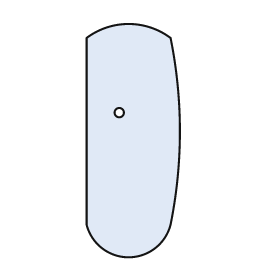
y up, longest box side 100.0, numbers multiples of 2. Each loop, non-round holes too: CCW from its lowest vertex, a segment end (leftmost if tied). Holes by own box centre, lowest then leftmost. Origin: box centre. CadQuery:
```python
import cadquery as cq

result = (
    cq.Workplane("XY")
    .moveTo(-20.0, -36.0)
    .threePointArc((-2.0, -50.0), (16.0, -36.0))
    .threePointArc((20.0, 4.0), (16.0, 44.0))
    .threePointArc((-2.0, 50.0), (-20.0, 44.0))
    .close()
    .moveTo(-6.0, 12.0)
    .circle(2.0)
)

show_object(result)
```